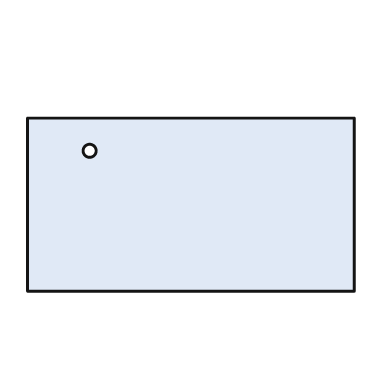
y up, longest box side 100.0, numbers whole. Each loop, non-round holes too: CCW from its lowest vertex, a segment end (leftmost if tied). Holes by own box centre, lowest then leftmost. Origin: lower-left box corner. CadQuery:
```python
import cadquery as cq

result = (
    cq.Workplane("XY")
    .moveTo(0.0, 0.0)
    .lineTo(100.0, 0.0)
    .lineTo(100.0, 53.0)
    .lineTo(0.0, 53.0)
    .close()
    .moveTo(19.0, 43.0)
    .circle(2.0)
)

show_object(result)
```